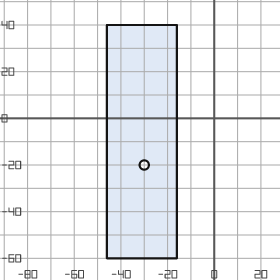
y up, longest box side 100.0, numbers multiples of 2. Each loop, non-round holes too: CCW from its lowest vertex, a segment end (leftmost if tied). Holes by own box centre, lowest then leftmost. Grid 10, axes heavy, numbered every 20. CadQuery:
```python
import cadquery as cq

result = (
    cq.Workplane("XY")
    .moveTo(-46.0, -60.0)
    .lineTo(-16.0, -60.0)
    .lineTo(-16.0, 40.0)
    .lineTo(-46.0, 40.0)
    .close()
    .moveTo(-30.0, -20.0)
    .circle(2.0)
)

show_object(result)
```